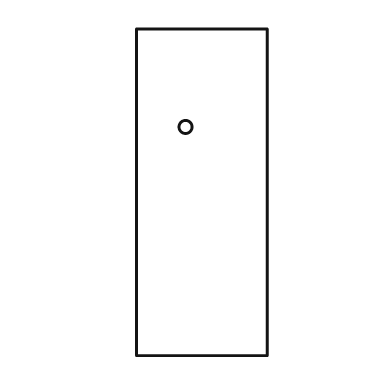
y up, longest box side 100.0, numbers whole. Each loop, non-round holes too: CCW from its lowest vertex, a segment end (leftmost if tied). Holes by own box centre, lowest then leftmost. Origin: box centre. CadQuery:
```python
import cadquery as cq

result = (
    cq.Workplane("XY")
    .moveTo(-20.0, -50.0)
    .lineTo(20.0, -50.0)
    .lineTo(20.0, 50.0)
    .lineTo(-20.0, 50.0)
    .close()
    .moveTo(-5.0, 20.0)
    .circle(2.0)
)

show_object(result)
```